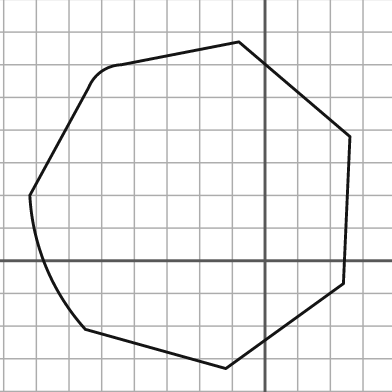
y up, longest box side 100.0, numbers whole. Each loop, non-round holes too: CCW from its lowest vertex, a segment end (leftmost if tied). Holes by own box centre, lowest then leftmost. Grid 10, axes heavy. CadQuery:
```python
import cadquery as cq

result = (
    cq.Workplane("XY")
    .moveTo(-12.0, -33.0)
    .lineTo(24.0, -7.0)
    .lineTo(26.0, 38.0)
    .lineTo(-8.0, 67.0)
    .lineTo(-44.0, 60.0)
    .threePointArc((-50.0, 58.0), (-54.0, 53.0))
    .lineTo(-72.0, 20.0)
    .threePointArc((-67.0, -2.0), (-55.0, -21.0))
    .close()
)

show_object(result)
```